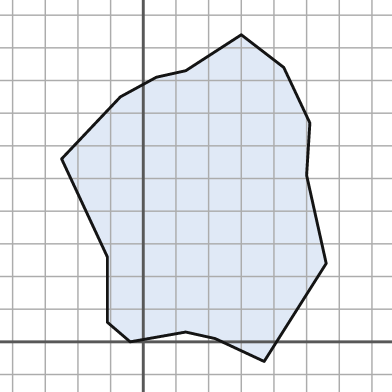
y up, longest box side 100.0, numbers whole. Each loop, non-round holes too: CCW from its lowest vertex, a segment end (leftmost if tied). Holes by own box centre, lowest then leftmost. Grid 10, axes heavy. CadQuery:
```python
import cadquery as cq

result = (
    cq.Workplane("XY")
    .moveTo(37.0, -6.0)
    .lineTo(56.0, 24.0)
    .lineTo(50.0, 51.0)
    .lineTo(51.0, 67.0)
    .lineTo(43.0, 84.0)
    .lineTo(30.0, 94.0)
    .lineTo(13.0, 83.0)
    .lineTo(4.0, 81.0)
    .lineTo(-7.0, 75.0)
    .lineTo(-25.0, 56.0)
    .lineTo(-11.0, 26.0)
    .lineTo(-11.0, 6.0)
    .lineTo(-4.0, 0.0)
    .lineTo(13.0, 3.0)
    .lineTo(22.0, 1.0)
    .close()
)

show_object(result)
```